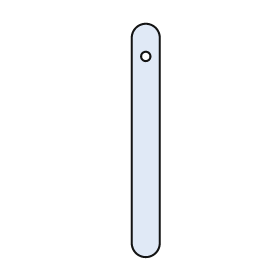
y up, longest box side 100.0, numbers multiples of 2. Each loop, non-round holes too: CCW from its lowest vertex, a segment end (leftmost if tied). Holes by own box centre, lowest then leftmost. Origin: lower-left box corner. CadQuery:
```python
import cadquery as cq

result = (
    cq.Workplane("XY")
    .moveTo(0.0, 6.0)
    .threePointArc((6.0, 0.0), (12.0, 6.0))
    .lineTo(12.0, 94.0)
    .threePointArc((6.0, 100.0), (0.0, 94.0))
    .close()
    .moveTo(6.0, 86.0)
    .circle(2.0)
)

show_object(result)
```